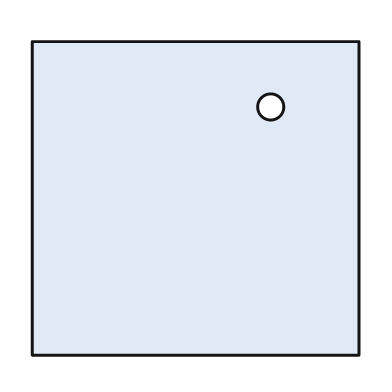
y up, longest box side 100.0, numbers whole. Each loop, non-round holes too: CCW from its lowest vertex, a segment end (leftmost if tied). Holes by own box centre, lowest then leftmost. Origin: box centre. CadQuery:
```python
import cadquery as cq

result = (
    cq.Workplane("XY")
    .moveTo(-50.0, -48.0)
    .lineTo(50.0, -48.0)
    .lineTo(50.0, 48.0)
    .lineTo(-50.0, 48.0)
    .close()
    .moveTo(23.0, 28.0)
    .circle(4.0)
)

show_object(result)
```